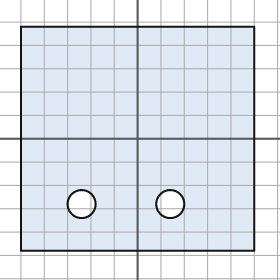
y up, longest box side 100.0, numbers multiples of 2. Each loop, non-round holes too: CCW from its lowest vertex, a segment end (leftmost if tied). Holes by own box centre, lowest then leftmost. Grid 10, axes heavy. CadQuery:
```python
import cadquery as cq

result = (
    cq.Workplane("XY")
    .moveTo(-50.0, -48.0)
    .lineTo(50.0, -48.0)
    .lineTo(50.0, 48.0)
    .lineTo(-50.0, 48.0)
    .close()
    .moveTo(-24.0, -28.0)
    .circle(6.0)
    .moveTo(14.0, -28.0)
    .circle(6.0)
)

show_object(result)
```